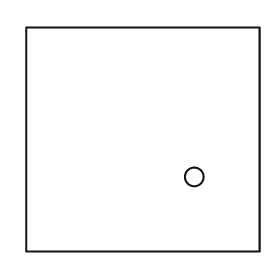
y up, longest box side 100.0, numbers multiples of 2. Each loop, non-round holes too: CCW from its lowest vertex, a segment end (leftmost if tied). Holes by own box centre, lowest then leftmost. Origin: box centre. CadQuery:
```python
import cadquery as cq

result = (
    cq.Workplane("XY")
    .moveTo(-50.0, -48.0)
    .lineTo(50.0, -48.0)
    .lineTo(50.0, 48.0)
    .lineTo(-50.0, 48.0)
    .close()
    .moveTo(22.0, -16.0)
    .circle(4.0)
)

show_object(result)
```